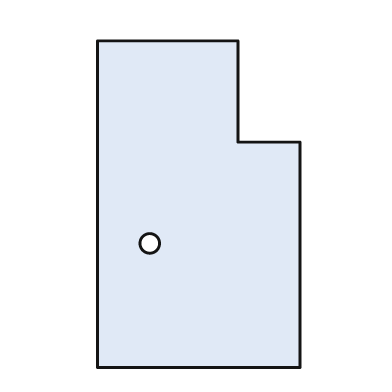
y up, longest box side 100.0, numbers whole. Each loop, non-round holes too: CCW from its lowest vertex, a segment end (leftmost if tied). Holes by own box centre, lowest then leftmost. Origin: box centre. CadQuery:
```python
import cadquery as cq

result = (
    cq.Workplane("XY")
    .moveTo(-31.0, -50.0)
    .lineTo(31.0, -50.0)
    .lineTo(31.0, 19.0)
    .lineTo(12.0, 19.0)
    .lineTo(12.0, 50.0)
    .lineTo(-31.0, 50.0)
    .close()
    .moveTo(-15.0, -12.0)
    .circle(3.0)
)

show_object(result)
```